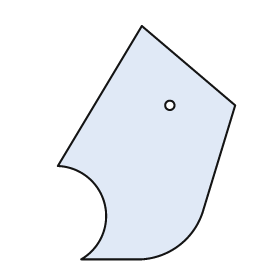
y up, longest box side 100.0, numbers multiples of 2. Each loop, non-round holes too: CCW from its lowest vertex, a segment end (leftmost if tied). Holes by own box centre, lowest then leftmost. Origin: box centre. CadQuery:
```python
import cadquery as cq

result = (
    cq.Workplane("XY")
    .moveTo(-28.0, -50.0)
    .lineTo(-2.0, -50.0)
    .threePointArc((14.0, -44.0), (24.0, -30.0))
    .lineTo(38.0, 16.0)
    .lineTo(-2.0, 50.0)
    .lineTo(-38.0, -10.0)
    .threePointArc((-18.0, -26.0), (-28.0, -50.0))
    .close()
    .moveTo(10.0, 16.0)
    .circle(2.0)
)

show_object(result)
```